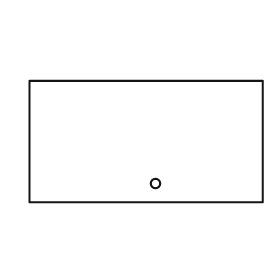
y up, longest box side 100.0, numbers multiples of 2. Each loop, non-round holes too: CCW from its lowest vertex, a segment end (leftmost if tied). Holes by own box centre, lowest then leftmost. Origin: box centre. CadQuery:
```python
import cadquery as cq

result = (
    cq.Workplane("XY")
    .moveTo(-50.0, -26.0)
    .lineTo(50.0, -26.0)
    .lineTo(50.0, 26.0)
    .lineTo(-50.0, 26.0)
    .close()
    .moveTo(4.0, -18.0)
    .circle(2.0)
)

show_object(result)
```